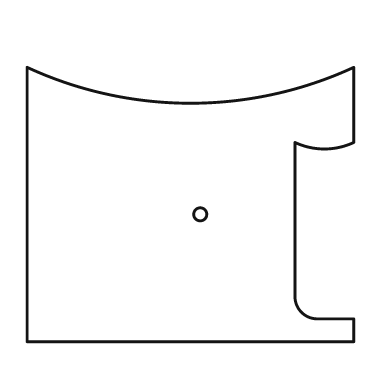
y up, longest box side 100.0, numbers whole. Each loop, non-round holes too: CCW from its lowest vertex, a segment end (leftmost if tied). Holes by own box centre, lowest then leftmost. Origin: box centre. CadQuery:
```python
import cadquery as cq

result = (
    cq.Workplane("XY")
    .moveTo(-50.0, -42.0)
    .lineTo(50.0, -42.0)
    .lineTo(50.0, -35.0)
    .lineTo(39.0, -35.0)
    .threePointArc((34.0, -33.0), (32.0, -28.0))
    .lineTo(32.0, 19.0)
    .threePointArc((41.0, 17.0), (50.0, 19.0))
    .lineTo(50.0, 42.0)
    .threePointArc((0.0, 31.0), (-50.0, 42.0))
    .close()
    .moveTo(3.0, -3.0)
    .circle(2.0)
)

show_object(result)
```